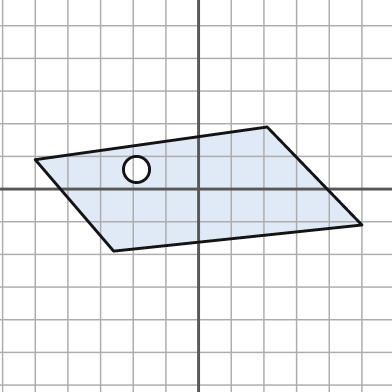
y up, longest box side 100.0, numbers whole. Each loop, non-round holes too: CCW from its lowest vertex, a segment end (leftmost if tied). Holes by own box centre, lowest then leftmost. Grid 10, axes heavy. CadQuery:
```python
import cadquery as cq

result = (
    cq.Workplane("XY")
    .moveTo(-26.0, -19.0)
    .lineTo(50.0, -11.0)
    .lineTo(21.0, 19.0)
    .lineTo(-50.0, 9.0)
    .close()
    .moveTo(-19.0, 6.0)
    .circle(4.0)
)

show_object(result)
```